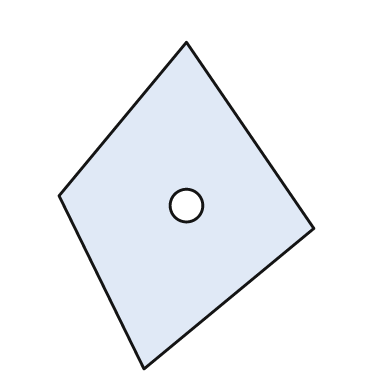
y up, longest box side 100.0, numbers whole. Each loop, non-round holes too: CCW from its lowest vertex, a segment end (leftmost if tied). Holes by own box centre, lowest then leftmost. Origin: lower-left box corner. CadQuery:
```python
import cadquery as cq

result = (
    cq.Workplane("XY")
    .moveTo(26.0, 0.0)
    .lineTo(78.0, 43.0)
    .lineTo(39.0, 100.0)
    .lineTo(0.0, 53.0)
    .close()
    .moveTo(39.0, 50.0)
    .circle(5.0)
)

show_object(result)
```